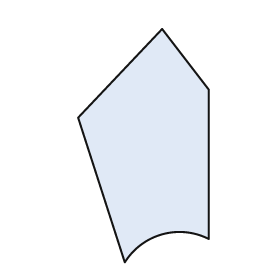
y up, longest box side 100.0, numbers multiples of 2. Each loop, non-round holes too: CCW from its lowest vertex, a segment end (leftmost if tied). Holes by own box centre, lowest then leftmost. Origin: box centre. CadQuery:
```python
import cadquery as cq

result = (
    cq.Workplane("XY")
    .moveTo(-8.0, -50.0)
    .threePointArc((8.0, -38.0), (28.0, -40.0))
    .lineTo(28.0, 24.0)
    .lineTo(8.0, 50.0)
    .lineTo(-28.0, 12.0)
    .close()
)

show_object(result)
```